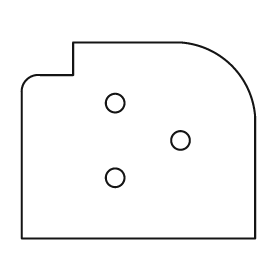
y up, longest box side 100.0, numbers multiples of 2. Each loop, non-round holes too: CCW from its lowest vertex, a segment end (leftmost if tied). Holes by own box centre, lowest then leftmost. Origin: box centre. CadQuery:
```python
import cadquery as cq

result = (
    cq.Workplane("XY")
    .moveTo(-50.0, -42.0)
    .lineTo(50.0, -42.0)
    .lineTo(50.0, 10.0)
    .threePointArc((40.0, 32.0), (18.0, 42.0))
    .lineTo(-28.0, 42.0)
    .lineTo(-28.0, 28.0)
    .lineTo(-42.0, 28.0)
    .threePointArc((-48.0, 26.0), (-50.0, 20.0))
    .close()
    .moveTo(-10.0, -16.0)
    .circle(4.0)
    .moveTo(18.0, 0.0)
    .circle(4.0)
    .moveTo(-10.0, 16.0)
    .circle(4.0)
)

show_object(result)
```